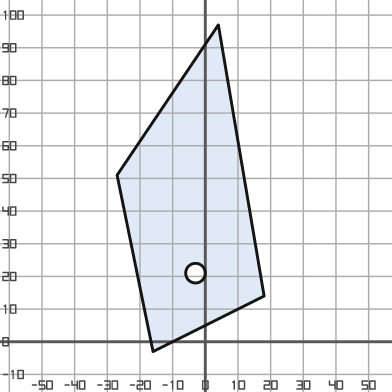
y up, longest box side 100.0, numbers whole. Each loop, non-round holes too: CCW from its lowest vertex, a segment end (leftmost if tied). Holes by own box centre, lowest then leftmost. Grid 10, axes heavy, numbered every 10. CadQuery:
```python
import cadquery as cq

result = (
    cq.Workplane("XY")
    .moveTo(-16.0, -3.0)
    .lineTo(18.0, 14.0)
    .lineTo(4.0, 97.0)
    .lineTo(-27.0, 51.0)
    .close()
    .moveTo(-3.0, 21.0)
    .circle(3.0)
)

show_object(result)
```